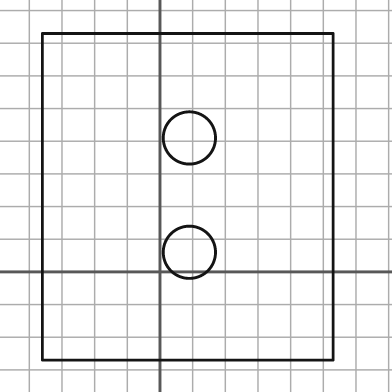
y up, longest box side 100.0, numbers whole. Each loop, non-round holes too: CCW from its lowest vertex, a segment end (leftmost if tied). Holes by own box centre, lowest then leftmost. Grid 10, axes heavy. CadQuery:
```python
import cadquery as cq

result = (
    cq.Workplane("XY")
    .moveTo(-36.0, -27.0)
    .lineTo(53.0, -27.0)
    .lineTo(53.0, 73.0)
    .lineTo(-36.0, 73.0)
    .close()
    .moveTo(9.0, 6.0)
    .circle(8.0)
    .moveTo(9.0, 41.0)
    .circle(8.0)
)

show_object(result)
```